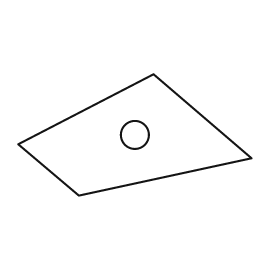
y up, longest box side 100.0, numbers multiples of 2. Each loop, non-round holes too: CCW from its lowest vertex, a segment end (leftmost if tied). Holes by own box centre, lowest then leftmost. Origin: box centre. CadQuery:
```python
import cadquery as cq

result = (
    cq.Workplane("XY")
    .moveTo(-24.0, -26.0)
    .lineTo(50.0, -10.0)
    .lineTo(8.0, 26.0)
    .lineTo(-50.0, -4.0)
    .close()
    .moveTo(0.0, 0.0)
    .circle(6.0)
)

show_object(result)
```